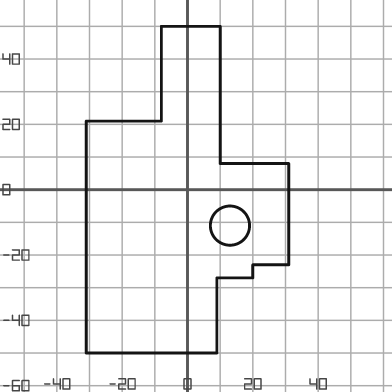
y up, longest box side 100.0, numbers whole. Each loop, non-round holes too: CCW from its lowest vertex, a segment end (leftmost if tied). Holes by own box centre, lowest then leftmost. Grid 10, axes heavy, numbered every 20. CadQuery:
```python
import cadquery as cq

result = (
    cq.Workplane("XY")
    .moveTo(-31.0, -50.0)
    .lineTo(9.0, -50.0)
    .lineTo(9.0, -27.0)
    .lineTo(20.0, -27.0)
    .lineTo(20.0, -23.0)
    .lineTo(31.0, -23.0)
    .lineTo(31.0, 8.0)
    .lineTo(10.0, 8.0)
    .lineTo(10.0, 50.0)
    .lineTo(-8.0, 50.0)
    .lineTo(-8.0, 21.0)
    .lineTo(-31.0, 21.0)
    .close()
    .moveTo(13.0, -11.0)
    .circle(6.0)
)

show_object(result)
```